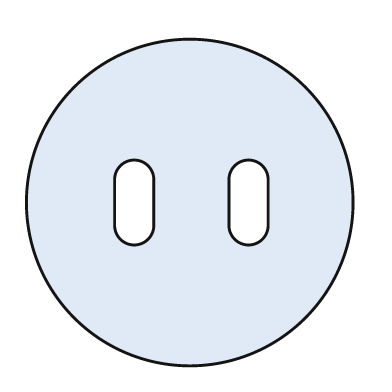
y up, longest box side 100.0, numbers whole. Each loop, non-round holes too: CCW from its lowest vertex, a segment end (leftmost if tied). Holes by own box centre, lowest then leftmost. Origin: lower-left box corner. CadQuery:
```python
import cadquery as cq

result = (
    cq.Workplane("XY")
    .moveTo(50.0, 50.0)
    .circle(50.0)
    .moveTo(27.0, 43.0)
    .threePointArc((33.0, 37.0), (39.0, 43.0))
    .lineTo(39.0, 57.0)
    .threePointArc((33.0, 63.0), (27.0, 57.0))
    .close()
    .moveTo(62.0, 43.0)
    .threePointArc((68.0, 37.0), (74.0, 43.0))
    .lineTo(74.0, 57.0)
    .threePointArc((68.0, 63.0), (62.0, 57.0))
    .close()
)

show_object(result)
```